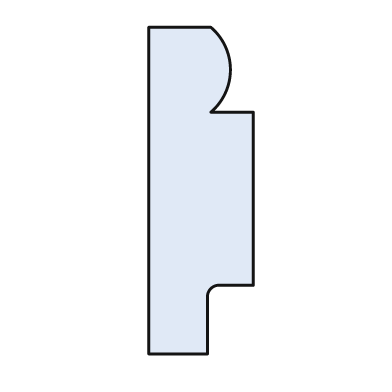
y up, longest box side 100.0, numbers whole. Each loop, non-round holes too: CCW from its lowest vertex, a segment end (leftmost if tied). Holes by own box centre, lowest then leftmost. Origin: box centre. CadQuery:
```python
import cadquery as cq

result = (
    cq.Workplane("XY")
    .moveTo(-16.0, -50.0)
    .lineTo(2.0, -50.0)
    .lineTo(2.0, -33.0)
    .threePointArc((3.0, -30.0), (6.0, -29.0))
    .lineTo(16.0, -29.0)
    .lineTo(16.0, 24.0)
    .lineTo(3.0, 24.0)
    .threePointArc((9.0, 37.0), (3.0, 50.0))
    .lineTo(-16.0, 50.0)
    .close()
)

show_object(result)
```